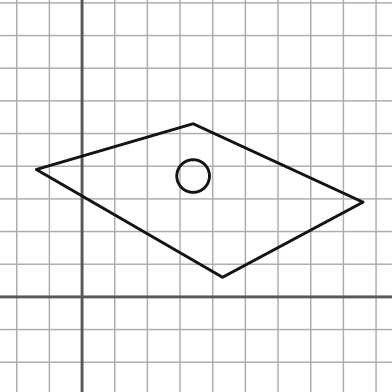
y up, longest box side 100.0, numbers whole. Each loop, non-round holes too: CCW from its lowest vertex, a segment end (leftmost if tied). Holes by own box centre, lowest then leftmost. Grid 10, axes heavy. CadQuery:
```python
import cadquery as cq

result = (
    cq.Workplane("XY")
    .moveTo(43.0, 6.0)
    .lineTo(86.0, 29.0)
    .lineTo(34.0, 53.0)
    .lineTo(-14.0, 39.0)
    .close()
    .moveTo(34.0, 37.0)
    .circle(5.0)
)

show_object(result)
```